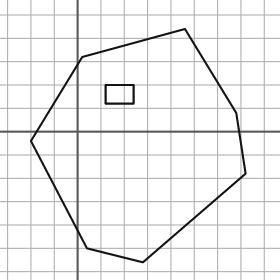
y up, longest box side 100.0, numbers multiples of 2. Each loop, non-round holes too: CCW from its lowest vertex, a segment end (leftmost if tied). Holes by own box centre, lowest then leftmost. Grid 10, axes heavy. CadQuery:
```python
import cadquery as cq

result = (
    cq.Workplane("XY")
    .moveTo(28.0, -56.0)
    .lineTo(72.0, -18.0)
    .lineTo(68.0, 8.0)
    .lineTo(46.0, 44.0)
    .lineTo(2.0, 32.0)
    .lineTo(-20.0, -4.0)
    .lineTo(4.0, -50.0)
    .close()
    .moveTo(12.0, 12.0)
    .lineTo(24.0, 12.0)
    .lineTo(24.0, 20.0)
    .lineTo(12.0, 20.0)
    .close()
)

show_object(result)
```